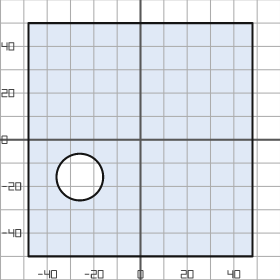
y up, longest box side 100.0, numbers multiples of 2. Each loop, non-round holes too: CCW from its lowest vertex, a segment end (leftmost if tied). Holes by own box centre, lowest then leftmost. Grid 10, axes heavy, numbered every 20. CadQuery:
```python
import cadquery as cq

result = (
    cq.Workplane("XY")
    .moveTo(-48.0, -50.0)
    .lineTo(48.0, -50.0)
    .lineTo(48.0, 50.0)
    .lineTo(-48.0, 50.0)
    .close()
    .moveTo(-26.0, -16.0)
    .circle(10.0)
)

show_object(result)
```